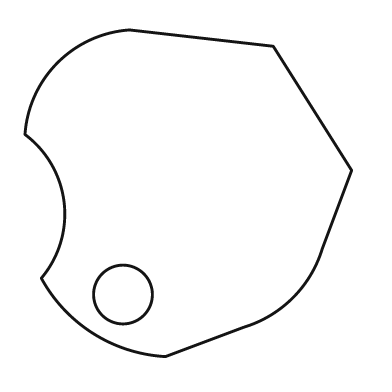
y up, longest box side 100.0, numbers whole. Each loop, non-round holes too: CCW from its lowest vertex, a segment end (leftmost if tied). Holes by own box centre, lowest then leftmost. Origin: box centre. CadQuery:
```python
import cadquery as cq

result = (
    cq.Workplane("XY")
    .moveTo(-7.0, -50.0)
    .lineTo(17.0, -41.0)
    .threePointArc((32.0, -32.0), (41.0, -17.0))
    .lineTo(50.0, 7.0)
    .lineTo(26.0, 45.0)
    .lineTo(-18.0, 50.0)
    .threePointArc((-40.0, 40.0), (-50.0, 18.0))
    .threePointArc((-38.0, -3.0), (-45.0, -26.0))
    .threePointArc((-29.0, -43.0), (-7.0, -50.0))
    .close()
    .moveTo(-20.0, -31.0)
    .circle(9.0)
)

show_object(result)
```